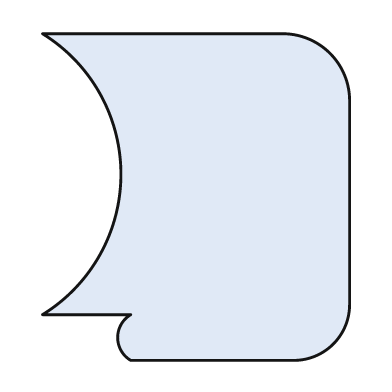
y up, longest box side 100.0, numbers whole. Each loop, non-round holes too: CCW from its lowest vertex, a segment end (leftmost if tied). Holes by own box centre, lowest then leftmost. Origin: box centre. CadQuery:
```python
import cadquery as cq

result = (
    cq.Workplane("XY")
    .moveTo(-20.0, -50.0)
    .lineTo(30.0, -50.0)
    .threePointArc((42.0, -45.0), (47.0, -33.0))
    .lineTo(47.0, 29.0)
    .threePointArc((41.0, 44.0), (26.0, 50.0))
    .lineTo(-47.0, 50.0)
    .threePointArc((-23.0, 7.0), (-47.0, -36.0))
    .lineTo(-20.0, -36.0)
    .threePointArc((-24.0, -43.0), (-20.0, -50.0))
    .close()
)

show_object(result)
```